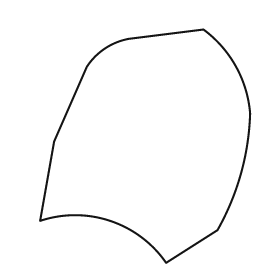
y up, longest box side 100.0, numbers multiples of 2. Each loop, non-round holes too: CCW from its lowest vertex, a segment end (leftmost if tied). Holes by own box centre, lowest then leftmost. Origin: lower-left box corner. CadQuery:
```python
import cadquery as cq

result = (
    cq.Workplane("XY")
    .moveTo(54.0, 0.0)
    .lineTo(76.0, 14.0)
    .threePointArc((86.0, 38.0), (90.0, 64.0))
    .threePointArc((84.0, 84.0), (70.0, 100.0))
    .lineTo(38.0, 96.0)
    .threePointArc((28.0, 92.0), (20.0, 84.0))
    .lineTo(6.0, 52.0)
    .lineTo(0.0, 18.0)
    .threePointArc((30.0, 18.0), (54.0, 0.0))
    .close()
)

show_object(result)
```